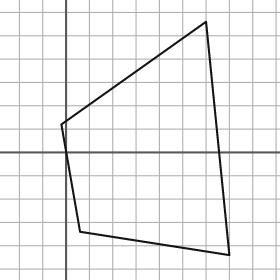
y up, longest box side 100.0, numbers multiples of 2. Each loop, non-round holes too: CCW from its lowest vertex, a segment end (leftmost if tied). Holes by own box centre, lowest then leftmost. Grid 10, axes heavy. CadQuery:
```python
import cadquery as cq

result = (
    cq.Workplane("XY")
    .moveTo(70.0, -44.0)
    .lineTo(60.0, 56.0)
    .lineTo(-2.0, 12.0)
    .lineTo(6.0, -34.0)
    .close()
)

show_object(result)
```